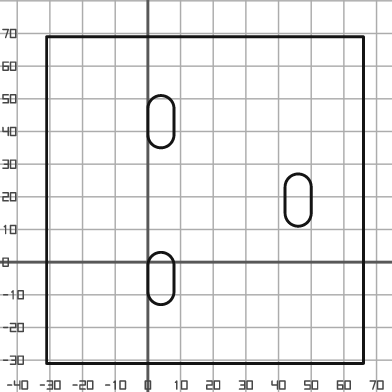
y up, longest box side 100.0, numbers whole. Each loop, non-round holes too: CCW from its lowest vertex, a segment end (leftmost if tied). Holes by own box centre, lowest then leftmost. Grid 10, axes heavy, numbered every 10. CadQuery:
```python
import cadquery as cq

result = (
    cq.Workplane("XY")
    .moveTo(-31.0, -31.0)
    .lineTo(66.0, -31.0)
    .lineTo(66.0, 69.0)
    .lineTo(-31.0, 69.0)
    .close()
    .moveTo(0.0, -9.0)
    .threePointArc((4.0, -13.0), (8.0, -9.0))
    .lineTo(8.0, -1.0)
    .threePointArc((4.0, 3.0), (0.0, -1.0))
    .close()
    .moveTo(42.0, 15.0)
    .threePointArc((46.0, 11.0), (50.0, 15.0))
    .lineTo(50.0, 23.0)
    .threePointArc((46.0, 27.0), (42.0, 23.0))
    .close()
    .moveTo(0.0, 39.0)
    .threePointArc((4.0, 35.0), (8.0, 39.0))
    .lineTo(8.0, 47.0)
    .threePointArc((4.0, 51.0), (0.0, 47.0))
    .close()
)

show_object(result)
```